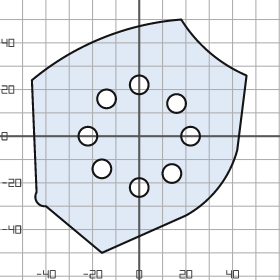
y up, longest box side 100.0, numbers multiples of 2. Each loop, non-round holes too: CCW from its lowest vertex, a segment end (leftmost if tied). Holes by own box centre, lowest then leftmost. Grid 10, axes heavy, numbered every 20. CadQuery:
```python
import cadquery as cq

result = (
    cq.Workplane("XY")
    .moveTo(-16.0, -50.0)
    .lineTo(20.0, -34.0)
    .threePointArc((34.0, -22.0), (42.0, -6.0))
    .lineTo(46.0, 26.0)
    .threePointArc((30.0, 36.0), (18.0, 50.0))
    .threePointArc((-16.0, 42.0), (-46.0, 24.0))
    .lineTo(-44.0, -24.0)
    .threePointArc((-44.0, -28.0), (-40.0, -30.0))
    .close()
    .moveTo(0.0, -22.0)
    .circle(4.0)
    .moveTo(14.0, -16.0)
    .circle(4.0)
    .moveTo(-16.0, -14.0)
    .circle(4.0)
    .moveTo(-22.0, 0.0)
    .circle(4.0)
    .moveTo(22.0, 0.0)
    .circle(4.0)
    .moveTo(16.0, 14.0)
    .circle(4.0)
    .moveTo(-14.0, 16.0)
    .circle(4.0)
    .moveTo(0.0, 22.0)
    .circle(4.0)
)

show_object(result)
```